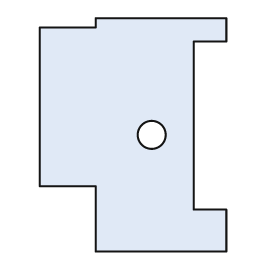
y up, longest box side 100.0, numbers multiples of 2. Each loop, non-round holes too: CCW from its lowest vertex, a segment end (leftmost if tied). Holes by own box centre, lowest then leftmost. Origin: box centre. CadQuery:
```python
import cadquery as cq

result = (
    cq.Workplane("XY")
    .moveTo(-16.0, -50.0)
    .lineTo(40.0, -50.0)
    .lineTo(40.0, -32.0)
    .lineTo(26.0, -32.0)
    .lineTo(26.0, 40.0)
    .lineTo(40.0, 40.0)
    .lineTo(40.0, 50.0)
    .lineTo(-16.0, 50.0)
    .lineTo(-16.0, 46.0)
    .lineTo(-40.0, 46.0)
    .lineTo(-40.0, -22.0)
    .lineTo(-16.0, -22.0)
    .close()
    .moveTo(8.0, 0.0)
    .circle(6.0)
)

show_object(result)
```